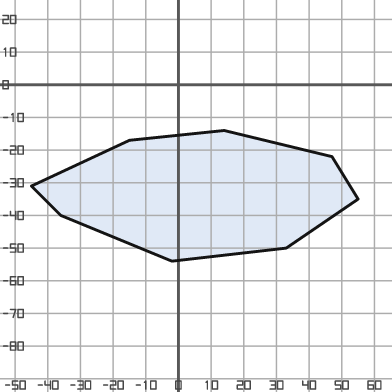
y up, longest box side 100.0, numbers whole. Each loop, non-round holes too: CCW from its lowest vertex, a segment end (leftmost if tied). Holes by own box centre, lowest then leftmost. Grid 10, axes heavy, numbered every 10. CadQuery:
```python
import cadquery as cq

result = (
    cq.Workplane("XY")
    .moveTo(-2.0, -54.0)
    .lineTo(33.0, -50.0)
    .lineTo(55.0, -35.0)
    .lineTo(47.0, -22.0)
    .lineTo(14.0, -14.0)
    .lineTo(-15.0, -17.0)
    .lineTo(-45.0, -31.0)
    .lineTo(-36.0, -40.0)
    .close()
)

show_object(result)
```